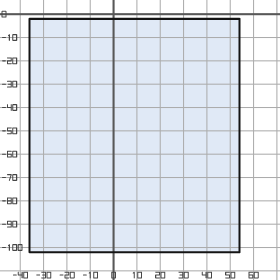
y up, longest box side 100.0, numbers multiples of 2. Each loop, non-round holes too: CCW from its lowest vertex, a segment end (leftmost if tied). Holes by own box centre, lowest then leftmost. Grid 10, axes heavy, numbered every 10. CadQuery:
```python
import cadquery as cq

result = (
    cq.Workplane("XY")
    .moveTo(-36.0, -102.0)
    .lineTo(54.0, -102.0)
    .lineTo(54.0, -2.0)
    .lineTo(-36.0, -2.0)
    .close()
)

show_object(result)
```